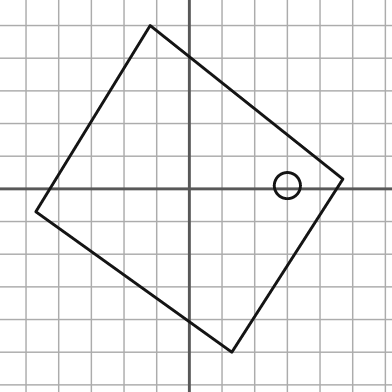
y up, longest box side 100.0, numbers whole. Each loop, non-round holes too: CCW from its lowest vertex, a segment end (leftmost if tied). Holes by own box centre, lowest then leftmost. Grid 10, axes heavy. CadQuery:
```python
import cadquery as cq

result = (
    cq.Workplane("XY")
    .moveTo(13.0, -50.0)
    .lineTo(47.0, 3.0)
    .lineTo(-12.0, 50.0)
    .lineTo(-47.0, -7.0)
    .close()
    .moveTo(30.0, 1.0)
    .circle(4.0)
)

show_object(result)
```